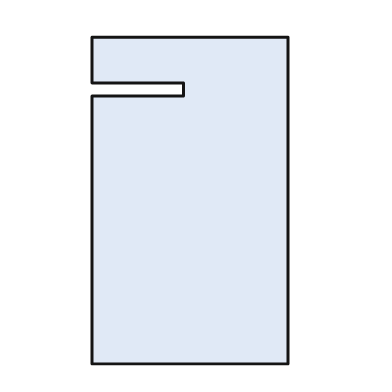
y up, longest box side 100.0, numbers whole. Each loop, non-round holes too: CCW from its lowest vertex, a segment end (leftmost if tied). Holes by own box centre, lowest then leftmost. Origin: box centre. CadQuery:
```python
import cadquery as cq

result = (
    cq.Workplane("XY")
    .moveTo(-30.0, -50.0)
    .lineTo(30.0, -50.0)
    .lineTo(30.0, 50.0)
    .lineTo(-30.0, 50.0)
    .lineTo(-30.0, 36.0)
    .lineTo(-2.0, 36.0)
    .lineTo(-2.0, 32.0)
    .lineTo(-30.0, 32.0)
    .close()
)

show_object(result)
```